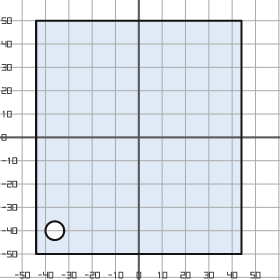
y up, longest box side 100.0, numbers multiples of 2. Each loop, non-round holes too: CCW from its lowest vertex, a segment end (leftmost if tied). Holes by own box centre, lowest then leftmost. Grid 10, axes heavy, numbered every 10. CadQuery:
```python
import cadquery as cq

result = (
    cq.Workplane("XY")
    .moveTo(-44.0, -50.0)
    .lineTo(44.0, -50.0)
    .lineTo(44.0, 50.0)
    .lineTo(-44.0, 50.0)
    .close()
    .moveTo(-36.0, -40.0)
    .circle(4.0)
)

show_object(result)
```